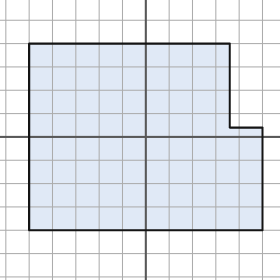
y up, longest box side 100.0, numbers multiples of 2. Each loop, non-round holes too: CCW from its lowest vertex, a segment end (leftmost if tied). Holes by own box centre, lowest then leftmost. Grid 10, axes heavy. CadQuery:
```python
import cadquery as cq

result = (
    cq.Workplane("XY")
    .moveTo(-50.0, -40.0)
    .lineTo(50.0, -40.0)
    .lineTo(50.0, 4.0)
    .lineTo(36.0, 4.0)
    .lineTo(36.0, 40.0)
    .lineTo(-50.0, 40.0)
    .close()
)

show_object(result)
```